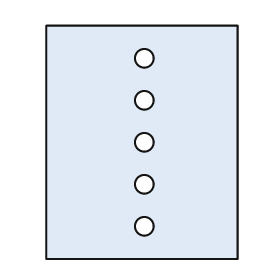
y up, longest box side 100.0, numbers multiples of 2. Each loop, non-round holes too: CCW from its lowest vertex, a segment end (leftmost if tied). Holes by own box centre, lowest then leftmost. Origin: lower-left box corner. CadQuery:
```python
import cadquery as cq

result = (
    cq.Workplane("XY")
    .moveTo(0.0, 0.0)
    .lineTo(82.0, 0.0)
    .lineTo(82.0, 100.0)
    .lineTo(0.0, 100.0)
    .close()
    .moveTo(42.0, 14.0)
    .circle(4.0)
    .moveTo(42.0, 32.0)
    .circle(4.0)
    .moveTo(42.0, 50.0)
    .circle(4.0)
    .moveTo(42.0, 68.0)
    .circle(4.0)
    .moveTo(42.0, 86.0)
    .circle(4.0)
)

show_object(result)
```